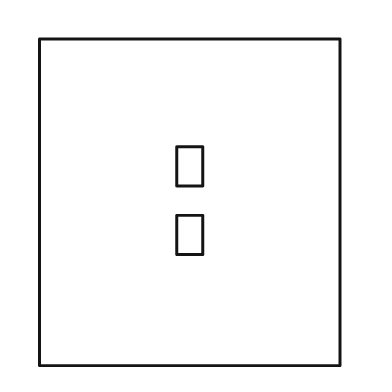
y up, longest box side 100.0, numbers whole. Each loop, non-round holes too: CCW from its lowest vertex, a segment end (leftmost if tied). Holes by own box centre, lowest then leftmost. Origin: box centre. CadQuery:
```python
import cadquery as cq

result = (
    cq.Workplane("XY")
    .moveTo(-46.0, -50.0)
    .lineTo(46.0, -50.0)
    .lineTo(46.0, 50.0)
    .lineTo(-46.0, 50.0)
    .close()
    .moveTo(-4.0, -16.0)
    .lineTo(4.0, -16.0)
    .lineTo(4.0, -4.0)
    .lineTo(-4.0, -4.0)
    .close()
    .moveTo(-4.0, 5.0)
    .lineTo(4.0, 5.0)
    .lineTo(4.0, 17.0)
    .lineTo(-4.0, 17.0)
    .close()
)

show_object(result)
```